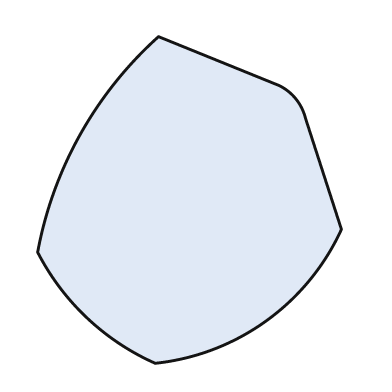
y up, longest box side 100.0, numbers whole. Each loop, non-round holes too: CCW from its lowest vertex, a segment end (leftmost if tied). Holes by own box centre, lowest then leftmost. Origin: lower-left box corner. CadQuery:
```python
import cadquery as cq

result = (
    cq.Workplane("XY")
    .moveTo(36.0, 0.0)
    .threePointArc((70.0, 13.0), (93.0, 41.0))
    .lineTo(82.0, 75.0)
    .threePointArc((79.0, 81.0), (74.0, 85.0))
    .lineTo(37.0, 100.0)
    .threePointArc((13.0, 70.0), (0.0, 34.0))
    .threePointArc((15.0, 14.0), (36.0, 0.0))
    .close()
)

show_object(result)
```